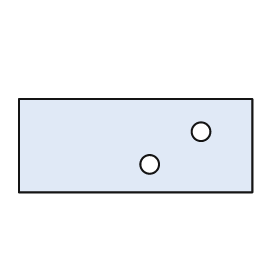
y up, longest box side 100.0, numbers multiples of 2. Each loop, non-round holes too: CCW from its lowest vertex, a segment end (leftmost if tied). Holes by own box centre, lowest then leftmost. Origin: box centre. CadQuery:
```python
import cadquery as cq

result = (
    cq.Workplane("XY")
    .moveTo(-50.0, -20.0)
    .lineTo(50.0, -20.0)
    .lineTo(50.0, 20.0)
    .lineTo(-50.0, 20.0)
    .close()
    .moveTo(6.0, -8.0)
    .circle(4.0)
    .moveTo(28.0, 6.0)
    .circle(4.0)
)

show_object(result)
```